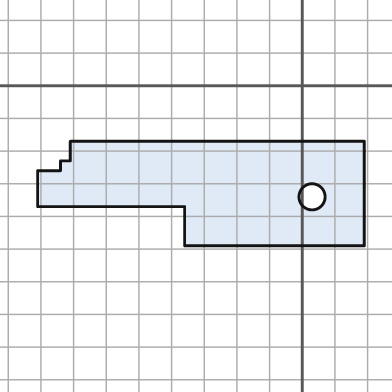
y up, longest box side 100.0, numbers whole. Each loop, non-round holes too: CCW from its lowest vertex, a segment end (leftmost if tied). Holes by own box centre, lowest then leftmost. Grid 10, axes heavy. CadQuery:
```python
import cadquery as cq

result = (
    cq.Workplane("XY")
    .moveTo(-36.0, -49.0)
    .lineTo(19.0, -49.0)
    .lineTo(19.0, -17.0)
    .lineTo(-71.0, -17.0)
    .lineTo(-71.0, -23.0)
    .lineTo(-74.0, -23.0)
    .lineTo(-74.0, -26.0)
    .lineTo(-81.0, -26.0)
    .lineTo(-81.0, -37.0)
    .lineTo(-36.0, -37.0)
    .close()
    .moveTo(3.0, -34.0)
    .circle(4.0)
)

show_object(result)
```